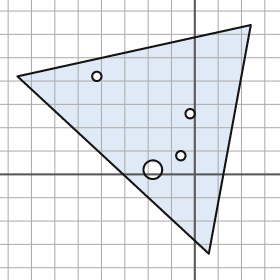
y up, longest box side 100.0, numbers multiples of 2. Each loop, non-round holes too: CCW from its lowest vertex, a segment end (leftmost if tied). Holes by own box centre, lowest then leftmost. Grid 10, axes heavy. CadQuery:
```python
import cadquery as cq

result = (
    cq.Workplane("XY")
    .moveTo(6.0, -34.0)
    .lineTo(24.0, 64.0)
    .lineTo(-76.0, 42.0)
    .close()
    .moveTo(-18.0, 2.0)
    .circle(4.0)
    .moveTo(-6.0, 8.0)
    .circle(2.0)
    .moveTo(-2.0, 26.0)
    .circle(2.0)
    .moveTo(-42.0, 42.0)
    .circle(2.0)
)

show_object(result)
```